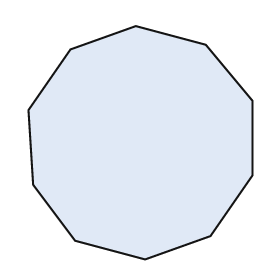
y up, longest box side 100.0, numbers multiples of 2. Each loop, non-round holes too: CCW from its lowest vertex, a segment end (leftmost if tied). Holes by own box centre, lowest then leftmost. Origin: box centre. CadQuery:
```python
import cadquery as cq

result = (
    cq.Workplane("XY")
    .moveTo(2.0, -50.0)
    .lineTo(30.0, -40.0)
    .lineTo(48.0, -14.0)
    .lineTo(48.0, 18.0)
    .lineTo(28.0, 42.0)
    .lineTo(-2.0, 50.0)
    .lineTo(-30.0, 40.0)
    .lineTo(-48.0, 14.0)
    .lineTo(-46.0, -18.0)
    .lineTo(-28.0, -42.0)
    .close()
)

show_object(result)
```